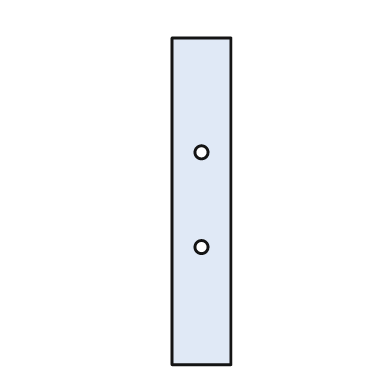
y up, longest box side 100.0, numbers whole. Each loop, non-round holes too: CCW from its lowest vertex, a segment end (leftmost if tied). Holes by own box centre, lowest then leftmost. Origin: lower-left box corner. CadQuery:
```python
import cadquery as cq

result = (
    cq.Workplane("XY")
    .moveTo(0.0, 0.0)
    .lineTo(18.0, 0.0)
    .lineTo(18.0, 100.0)
    .lineTo(0.0, 100.0)
    .close()
    .moveTo(9.0, 36.0)
    .circle(2.0)
    .moveTo(9.0, 65.0)
    .circle(2.0)
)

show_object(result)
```